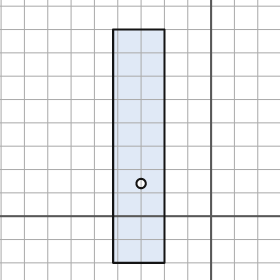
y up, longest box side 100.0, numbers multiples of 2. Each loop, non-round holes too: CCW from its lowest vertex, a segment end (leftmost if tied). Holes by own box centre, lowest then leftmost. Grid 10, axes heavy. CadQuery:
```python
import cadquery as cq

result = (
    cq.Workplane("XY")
    .moveTo(-42.0, -20.0)
    .lineTo(-20.0, -20.0)
    .lineTo(-20.0, 80.0)
    .lineTo(-42.0, 80.0)
    .close()
    .moveTo(-30.0, 14.0)
    .circle(2.0)
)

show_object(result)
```